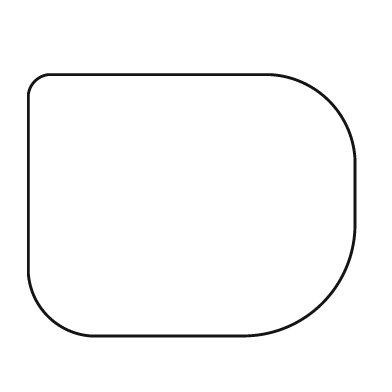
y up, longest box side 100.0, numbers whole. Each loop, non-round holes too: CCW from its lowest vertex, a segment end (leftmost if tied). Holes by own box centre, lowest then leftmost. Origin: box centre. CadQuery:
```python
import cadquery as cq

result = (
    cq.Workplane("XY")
    .moveTo(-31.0, -40.0)
    .lineTo(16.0, -40.0)
    .threePointArc((40.0, -30.0), (50.0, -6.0))
    .lineTo(50.0, 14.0)
    .threePointArc((42.0, 32.0), (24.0, 40.0))
    .lineTo(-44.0, 40.0)
    .threePointArc((-48.0, 38.0), (-50.0, 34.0))
    .lineTo(-50.0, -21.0)
    .threePointArc((-44.0, -34.0), (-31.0, -40.0))
    .close()
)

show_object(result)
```